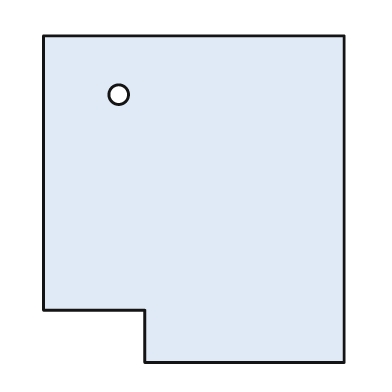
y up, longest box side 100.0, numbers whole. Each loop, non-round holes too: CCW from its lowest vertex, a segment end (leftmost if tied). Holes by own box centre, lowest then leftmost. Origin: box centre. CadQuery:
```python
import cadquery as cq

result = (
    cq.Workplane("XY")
    .moveTo(-15.0, -50.0)
    .lineTo(46.0, -50.0)
    .lineTo(46.0, 50.0)
    .lineTo(-46.0, 50.0)
    .lineTo(-46.0, -34.0)
    .lineTo(-15.0, -34.0)
    .close()
    .moveTo(-23.0, 32.0)
    .circle(3.0)
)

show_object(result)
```